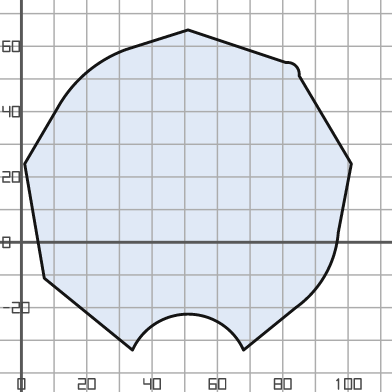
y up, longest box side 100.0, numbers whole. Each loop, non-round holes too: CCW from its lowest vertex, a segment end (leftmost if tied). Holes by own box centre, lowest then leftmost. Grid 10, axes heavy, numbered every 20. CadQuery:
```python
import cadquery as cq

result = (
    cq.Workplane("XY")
    .moveTo(34.0, -33.0)
    .threePointArc((51.0, -22.0), (68.0, -33.0))
    .lineTo(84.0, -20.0)
    .threePointArc((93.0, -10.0), (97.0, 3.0))
    .lineTo(101.0, 24.0)
    .lineTo(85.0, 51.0)
    .threePointArc((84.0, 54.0), (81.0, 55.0))
    .lineTo(51.0, 65.0)
    .lineTo(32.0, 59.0)
    .threePointArc((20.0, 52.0), (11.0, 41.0))
    .lineTo(1.0, 24.0)
    .lineTo(7.0, -11.0)
    .close()
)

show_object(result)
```